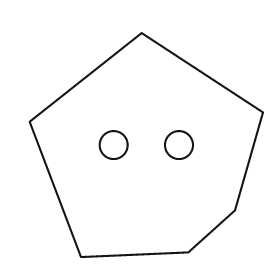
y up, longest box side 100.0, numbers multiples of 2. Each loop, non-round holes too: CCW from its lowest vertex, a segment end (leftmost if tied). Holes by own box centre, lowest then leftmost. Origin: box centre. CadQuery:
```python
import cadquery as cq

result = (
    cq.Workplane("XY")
    .moveTo(-28.0, -48.0)
    .lineTo(18.0, -46.0)
    .lineTo(38.0, -28.0)
    .lineTo(50.0, 14.0)
    .lineTo(-2.0, 48.0)
    .lineTo(-50.0, 10.0)
    .close()
    .moveTo(-14.0, 0.0)
    .circle(6.0)
    .moveTo(14.0, 0.0)
    .circle(6.0)
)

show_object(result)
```